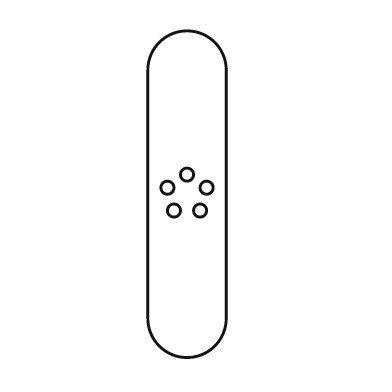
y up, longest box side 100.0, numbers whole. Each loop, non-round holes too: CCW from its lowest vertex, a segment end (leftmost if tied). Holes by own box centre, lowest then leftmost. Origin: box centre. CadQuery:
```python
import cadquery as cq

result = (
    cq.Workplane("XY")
    .moveTo(-12.0, -38.0)
    .threePointArc((0.0, -50.0), (12.0, -38.0))
    .lineTo(12.0, 38.0)
    .threePointArc((0.0, 50.0), (-12.0, 38.0))
    .close()
    .moveTo(-4.0, -5.0)
    .circle(2.0)
    .moveTo(4.0, -5.0)
    .circle(2.0)
    .moveTo(-6.0, 2.0)
    .circle(2.0)
    .moveTo(6.0, 2.0)
    .circle(2.0)
    .moveTo(0.0, 6.0)
    .circle(2.0)
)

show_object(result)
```